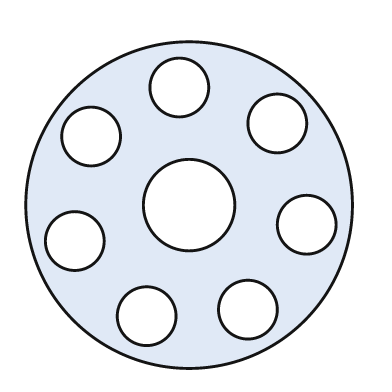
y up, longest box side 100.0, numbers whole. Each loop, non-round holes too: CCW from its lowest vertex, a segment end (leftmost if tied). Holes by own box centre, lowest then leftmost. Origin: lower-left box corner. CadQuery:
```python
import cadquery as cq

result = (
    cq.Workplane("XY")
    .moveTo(50.0, 50.0)
    .circle(50.0)
    .moveTo(37.0, 16.0)
    .circle(9.0)
    .moveTo(68.0, 18.0)
    .circle(9.0)
    .moveTo(15.0, 39.0)
    .circle(9.0)
    .moveTo(86.0, 44.0)
    .circle(9.0)
    .moveTo(50.0, 50.0)
    .circle(14.0)
    .moveTo(20.0, 71.0)
    .circle(9.0)
    .moveTo(77.0, 75.0)
    .circle(9.0)
    .moveTo(47.0, 86.0)
    .circle(9.0)
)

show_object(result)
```